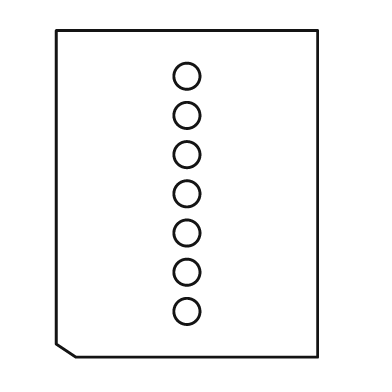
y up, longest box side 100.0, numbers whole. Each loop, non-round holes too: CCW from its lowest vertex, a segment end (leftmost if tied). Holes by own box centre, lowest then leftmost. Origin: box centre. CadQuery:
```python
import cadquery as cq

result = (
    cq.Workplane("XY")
    .moveTo(-34.0, -50.0)
    .lineTo(40.0, -50.0)
    .lineTo(40.0, 50.0)
    .lineTo(-40.0, 50.0)
    .lineTo(-40.0, -46.0)
    .close()
    .moveTo(0.0, -36.0)
    .circle(4.0)
    .moveTo(0.0, -24.0)
    .circle(4.0)
    .moveTo(0.0, -12.0)
    .circle(4.0)
    .moveTo(0.0, 0.0)
    .circle(4.0)
    .moveTo(0.0, 12.0)
    .circle(4.0)
    .moveTo(0.0, 24.0)
    .circle(4.0)
    .moveTo(0.0, 36.0)
    .circle(4.0)
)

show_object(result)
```